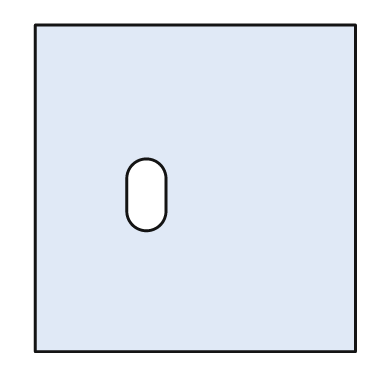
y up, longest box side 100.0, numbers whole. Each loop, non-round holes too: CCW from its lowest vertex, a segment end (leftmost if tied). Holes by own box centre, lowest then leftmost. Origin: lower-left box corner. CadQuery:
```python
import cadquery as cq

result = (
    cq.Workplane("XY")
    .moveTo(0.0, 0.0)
    .lineTo(98.0, 0.0)
    .lineTo(98.0, 100.0)
    .lineTo(0.0, 100.0)
    .close()
    .moveTo(28.0, 43.0)
    .threePointArc((34.0, 37.0), (40.0, 43.0))
    .lineTo(40.0, 53.0)
    .threePointArc((34.0, 59.0), (28.0, 53.0))
    .close()
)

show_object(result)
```